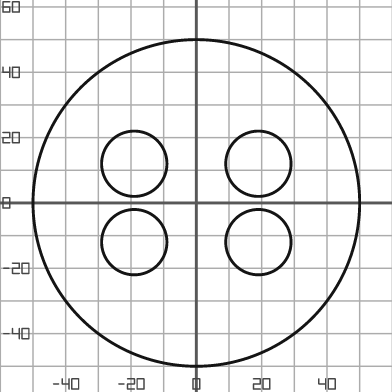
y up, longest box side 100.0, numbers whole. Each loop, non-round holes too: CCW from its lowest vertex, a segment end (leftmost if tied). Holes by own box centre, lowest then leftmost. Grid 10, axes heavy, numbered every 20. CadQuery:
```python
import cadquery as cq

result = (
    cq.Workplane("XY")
    .moveTo(0.0, 0.0)
    .circle(50.0)
    .moveTo(-19.0, -12.0)
    .circle(10.0)
    .moveTo(19.0, -12.0)
    .circle(10.0)
    .moveTo(-19.0, 12.0)
    .circle(10.0)
    .moveTo(19.0, 12.0)
    .circle(10.0)
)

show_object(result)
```